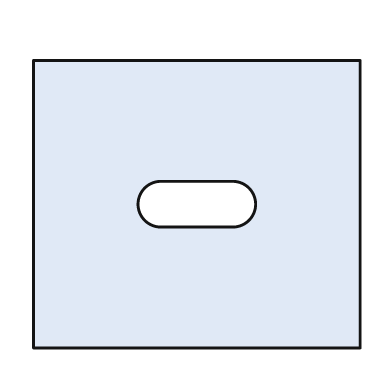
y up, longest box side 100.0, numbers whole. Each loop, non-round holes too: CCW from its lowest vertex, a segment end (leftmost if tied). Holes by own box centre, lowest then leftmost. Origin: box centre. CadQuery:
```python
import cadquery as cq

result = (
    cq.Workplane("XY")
    .moveTo(-50.0, -44.0)
    .lineTo(50.0, -44.0)
    .lineTo(50.0, 44.0)
    .lineTo(-50.0, 44.0)
    .close()
    .moveTo(-11.0, -7.0)
    .lineTo(11.0, -7.0)
    .threePointArc((18.0, 0.0), (11.0, 7.0))
    .lineTo(-11.0, 7.0)
    .threePointArc((-18.0, 0.0), (-11.0, -7.0))
    .close()
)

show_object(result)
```